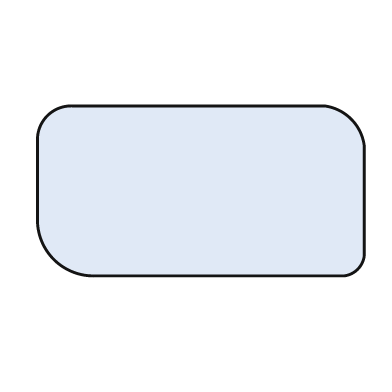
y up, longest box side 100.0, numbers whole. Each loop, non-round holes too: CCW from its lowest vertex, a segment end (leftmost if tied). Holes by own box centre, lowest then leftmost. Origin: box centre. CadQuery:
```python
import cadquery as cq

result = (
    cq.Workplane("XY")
    .moveTo(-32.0, -26.0)
    .lineTo(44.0, -26.0)
    .threePointArc((48.0, -24.0), (50.0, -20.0))
    .lineTo(50.0, 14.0)
    .threePointArc((46.0, 22.0), (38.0, 26.0))
    .lineTo(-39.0, 26.0)
    .threePointArc((-47.0, 23.0), (-50.0, 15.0))
    .lineTo(-50.0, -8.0)
    .threePointArc((-45.0, -21.0), (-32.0, -26.0))
    .close()
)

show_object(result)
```